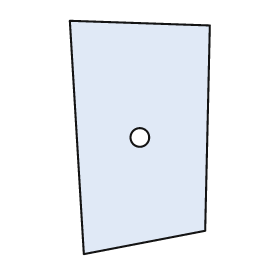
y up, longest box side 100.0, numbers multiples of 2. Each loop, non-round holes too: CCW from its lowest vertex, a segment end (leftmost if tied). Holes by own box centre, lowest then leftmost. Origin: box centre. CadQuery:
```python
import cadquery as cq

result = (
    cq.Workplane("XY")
    .moveTo(-24.0, -50.0)
    .lineTo(28.0, -40.0)
    .lineTo(30.0, 48.0)
    .lineTo(-30.0, 50.0)
    .close()
    .moveTo(0.0, 0.0)
    .circle(4.0)
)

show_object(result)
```